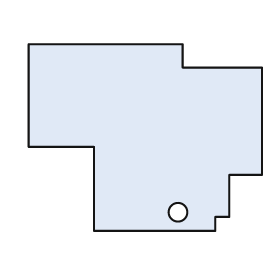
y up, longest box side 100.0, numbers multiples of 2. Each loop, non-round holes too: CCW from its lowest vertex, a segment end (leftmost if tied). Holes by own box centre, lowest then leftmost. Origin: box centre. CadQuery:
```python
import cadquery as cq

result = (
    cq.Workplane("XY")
    .moveTo(-22.0, -40.0)
    .lineTo(30.0, -40.0)
    .lineTo(30.0, -34.0)
    .lineTo(36.0, -34.0)
    .lineTo(36.0, -16.0)
    .lineTo(50.0, -16.0)
    .lineTo(50.0, 30.0)
    .lineTo(16.0, 30.0)
    .lineTo(16.0, 40.0)
    .lineTo(-50.0, 40.0)
    .lineTo(-50.0, -4.0)
    .lineTo(-22.0, -4.0)
    .close()
    .moveTo(14.0, -32.0)
    .circle(4.0)
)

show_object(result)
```